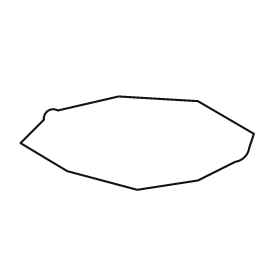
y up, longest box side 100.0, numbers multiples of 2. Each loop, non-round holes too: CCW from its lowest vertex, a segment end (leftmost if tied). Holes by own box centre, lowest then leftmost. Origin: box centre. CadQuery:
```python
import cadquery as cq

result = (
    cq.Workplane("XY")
    .moveTo(0.0, -20.0)
    .lineTo(26.0, -16.0)
    .lineTo(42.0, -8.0)
    .threePointArc((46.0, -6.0), (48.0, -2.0))
    .lineTo(50.0, 4.0)
    .lineTo(26.0, 18.0)
    .lineTo(-8.0, 20.0)
    .lineTo(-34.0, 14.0)
    .threePointArc((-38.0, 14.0), (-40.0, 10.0))
    .lineTo(-50.0, 0.0)
    .lineTo(-30.0, -12.0)
    .close()
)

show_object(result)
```